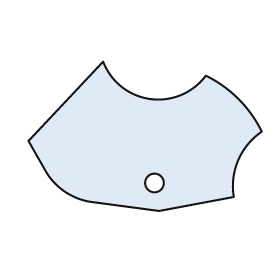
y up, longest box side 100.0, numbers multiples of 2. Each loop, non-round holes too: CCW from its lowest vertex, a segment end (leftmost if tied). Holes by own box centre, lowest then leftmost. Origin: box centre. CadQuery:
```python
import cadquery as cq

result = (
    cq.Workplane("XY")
    .moveTo(6.0, -32.0)
    .lineTo(38.0, -26.0)
    .threePointArc((40.0, -10.0), (50.0, 2.0))
    .threePointArc((40.0, 16.0), (26.0, 26.0))
    .threePointArc((2.0, 16.0), (-18.0, 32.0))
    .lineTo(-50.0, -2.0)
    .lineTo(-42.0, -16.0)
    .threePointArc((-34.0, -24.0), (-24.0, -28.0))
    .close()
    .moveTo(4.0, -20.0)
    .circle(4.0)
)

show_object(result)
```